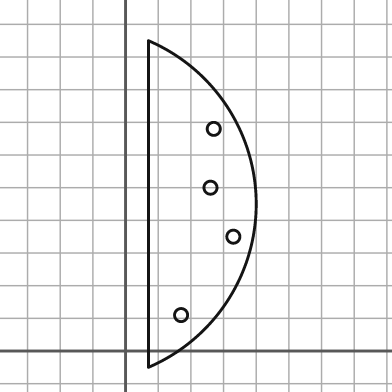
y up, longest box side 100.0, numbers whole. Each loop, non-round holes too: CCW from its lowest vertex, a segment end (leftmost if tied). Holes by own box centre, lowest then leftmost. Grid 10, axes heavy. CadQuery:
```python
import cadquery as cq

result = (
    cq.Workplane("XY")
    .moveTo(7.0, -5.0)
    .threePointArc((40.0, 45.0), (7.0, 95.0))
    .close()
    .moveTo(17.0, 11.0)
    .circle(2.0)
    .moveTo(33.0, 35.0)
    .circle(2.0)
    .moveTo(26.0, 50.0)
    .circle(2.0)
    .moveTo(27.0, 68.0)
    .circle(2.0)
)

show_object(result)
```